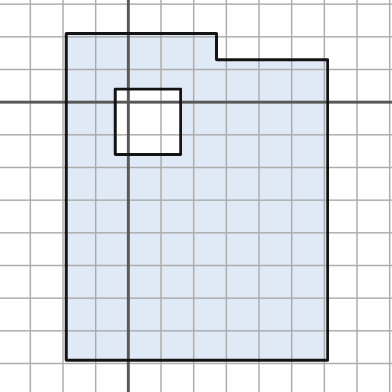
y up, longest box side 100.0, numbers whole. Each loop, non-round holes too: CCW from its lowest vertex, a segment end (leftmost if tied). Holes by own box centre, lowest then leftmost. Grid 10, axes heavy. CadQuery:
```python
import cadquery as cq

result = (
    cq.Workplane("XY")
    .moveTo(-19.0, -79.0)
    .lineTo(61.0, -79.0)
    .lineTo(61.0, 13.0)
    .lineTo(27.0, 13.0)
    .lineTo(27.0, 21.0)
    .lineTo(-19.0, 21.0)
    .close()
    .moveTo(-4.0, -16.0)
    .lineTo(16.0, -16.0)
    .lineTo(16.0, 4.0)
    .lineTo(-4.0, 4.0)
    .close()
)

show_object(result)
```